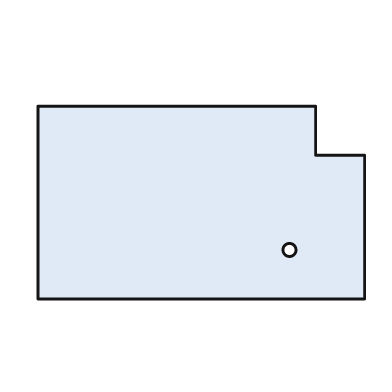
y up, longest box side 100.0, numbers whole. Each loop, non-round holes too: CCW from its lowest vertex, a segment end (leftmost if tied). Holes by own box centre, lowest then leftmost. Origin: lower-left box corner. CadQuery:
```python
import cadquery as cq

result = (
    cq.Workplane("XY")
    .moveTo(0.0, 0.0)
    .lineTo(100.0, 0.0)
    .lineTo(100.0, 44.0)
    .lineTo(85.0, 44.0)
    .lineTo(85.0, 59.0)
    .lineTo(0.0, 59.0)
    .close()
    .moveTo(77.0, 15.0)
    .circle(2.0)
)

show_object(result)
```